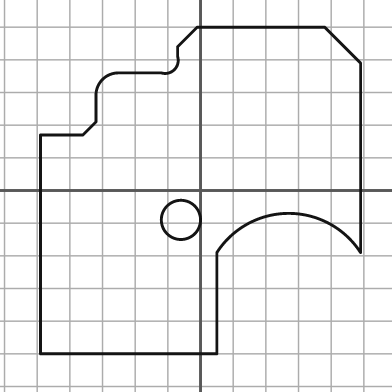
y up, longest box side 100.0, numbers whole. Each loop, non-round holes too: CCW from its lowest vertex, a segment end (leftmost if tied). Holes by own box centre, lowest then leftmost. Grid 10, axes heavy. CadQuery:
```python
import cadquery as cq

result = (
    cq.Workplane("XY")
    .moveTo(-49.0, -50.0)
    .lineTo(5.0, -50.0)
    .lineTo(5.0, -19.0)
    .threePointArc((27.0, -7.0), (49.0, -19.0))
    .lineTo(49.0, 39.0)
    .lineTo(38.0, 50.0)
    .lineTo(-1.0, 50.0)
    .lineTo(-7.0, 44.0)
    .lineTo(-7.0, 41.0)
    .threePointArc((-8.0, 37.0), (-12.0, 36.0))
    .lineTo(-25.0, 36.0)
    .threePointArc((-30.0, 34.0), (-32.0, 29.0))
    .lineTo(-32.0, 21.0)
    .lineTo(-36.0, 17.0)
    .lineTo(-49.0, 17.0)
    .close()
    .moveTo(-6.0, -9.0)
    .circle(6.0)
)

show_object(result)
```